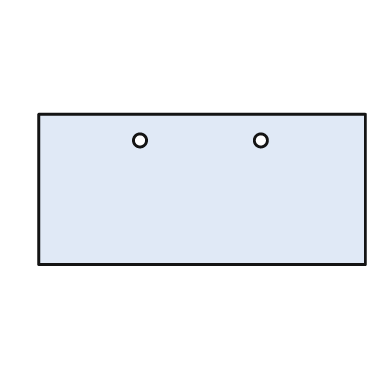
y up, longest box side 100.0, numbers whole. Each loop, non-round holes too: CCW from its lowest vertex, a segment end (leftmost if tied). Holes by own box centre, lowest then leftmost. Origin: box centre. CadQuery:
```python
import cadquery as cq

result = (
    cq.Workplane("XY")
    .moveTo(-50.0, -23.0)
    .lineTo(50.0, -23.0)
    .lineTo(50.0, 23.0)
    .lineTo(-50.0, 23.0)
    .close()
    .moveTo(-19.0, 15.0)
    .circle(2.0)
    .moveTo(18.0, 15.0)
    .circle(2.0)
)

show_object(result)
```